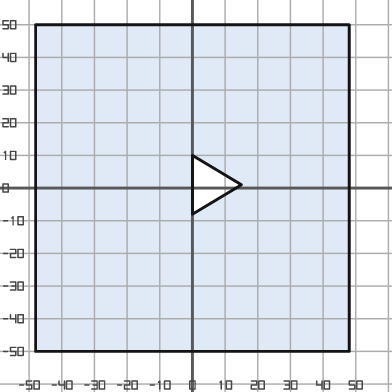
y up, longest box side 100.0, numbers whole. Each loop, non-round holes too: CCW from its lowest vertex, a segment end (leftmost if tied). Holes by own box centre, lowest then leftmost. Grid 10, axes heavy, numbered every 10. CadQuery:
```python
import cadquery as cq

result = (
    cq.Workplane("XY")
    .moveTo(-48.0, -50.0)
    .lineTo(48.0, -50.0)
    .lineTo(48.0, 50.0)
    .lineTo(-48.0, 50.0)
    .close()
    .moveTo(0.0, -8.0)
    .lineTo(15.0, 1.0)
    .lineTo(0.0, 10.0)
    .close()
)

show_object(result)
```